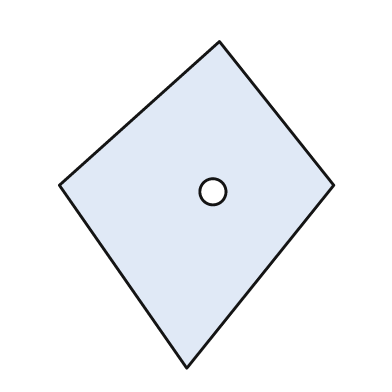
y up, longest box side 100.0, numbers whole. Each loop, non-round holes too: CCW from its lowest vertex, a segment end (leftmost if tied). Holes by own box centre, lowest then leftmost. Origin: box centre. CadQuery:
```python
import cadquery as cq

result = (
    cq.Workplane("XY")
    .moveTo(-3.0, -50.0)
    .lineTo(42.0, 6.0)
    .lineTo(7.0, 50.0)
    .lineTo(-42.0, 6.0)
    .close()
    .moveTo(5.0, 4.0)
    .circle(4.0)
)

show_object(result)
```